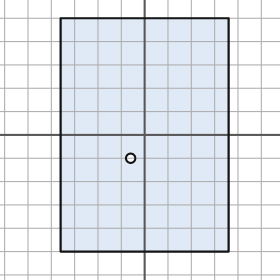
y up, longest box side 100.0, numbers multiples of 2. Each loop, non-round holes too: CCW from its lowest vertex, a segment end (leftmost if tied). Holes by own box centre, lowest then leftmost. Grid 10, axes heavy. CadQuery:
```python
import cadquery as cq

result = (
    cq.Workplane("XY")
    .moveTo(-36.0, -50.0)
    .lineTo(36.0, -50.0)
    .lineTo(36.0, 50.0)
    .lineTo(-36.0, 50.0)
    .close()
    .moveTo(-6.0, -10.0)
    .circle(2.0)
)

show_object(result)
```